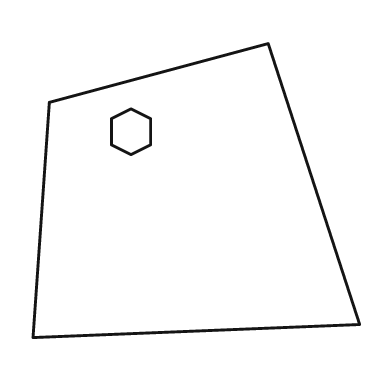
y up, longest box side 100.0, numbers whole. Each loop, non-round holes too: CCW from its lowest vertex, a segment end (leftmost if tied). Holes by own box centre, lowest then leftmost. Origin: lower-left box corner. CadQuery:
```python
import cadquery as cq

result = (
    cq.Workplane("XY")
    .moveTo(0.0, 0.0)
    .lineTo(100.0, 4.0)
    .lineTo(72.0, 90.0)
    .lineTo(5.0, 72.0)
    .close()
    .moveTo(30.0, 56.0)
    .lineTo(36.0, 59.0)
    .lineTo(36.0, 67.0)
    .lineTo(30.0, 70.0)
    .lineTo(24.0, 67.0)
    .lineTo(24.0, 59.0)
    .close()
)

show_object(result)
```